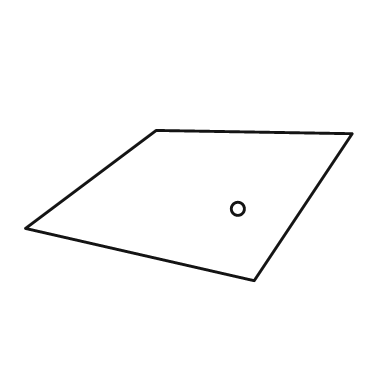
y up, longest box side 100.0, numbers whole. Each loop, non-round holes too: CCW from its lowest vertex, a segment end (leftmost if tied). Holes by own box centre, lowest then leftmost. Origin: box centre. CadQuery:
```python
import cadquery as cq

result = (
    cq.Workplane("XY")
    .moveTo(20.0, -23.0)
    .lineTo(50.0, 22.0)
    .lineTo(-10.0, 23.0)
    .lineTo(-50.0, -7.0)
    .close()
    .moveTo(15.0, -1.0)
    .circle(2.0)
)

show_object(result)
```